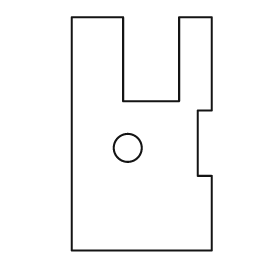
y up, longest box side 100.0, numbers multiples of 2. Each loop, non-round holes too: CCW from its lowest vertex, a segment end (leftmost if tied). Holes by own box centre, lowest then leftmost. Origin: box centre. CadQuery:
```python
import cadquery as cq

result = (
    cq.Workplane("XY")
    .moveTo(-30.0, -50.0)
    .lineTo(30.0, -50.0)
    .lineTo(30.0, -18.0)
    .lineTo(24.0, -18.0)
    .lineTo(24.0, 10.0)
    .lineTo(30.0, 10.0)
    .lineTo(30.0, 50.0)
    .lineTo(16.0, 50.0)
    .lineTo(16.0, 14.0)
    .lineTo(-8.0, 14.0)
    .lineTo(-8.0, 50.0)
    .lineTo(-30.0, 50.0)
    .close()
    .moveTo(-6.0, -6.0)
    .circle(6.0)
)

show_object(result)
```